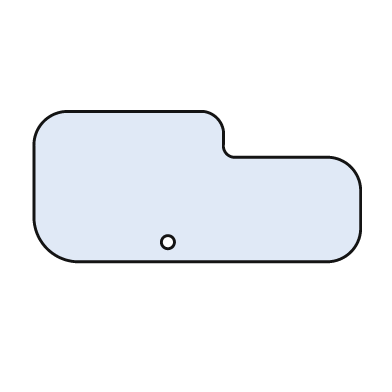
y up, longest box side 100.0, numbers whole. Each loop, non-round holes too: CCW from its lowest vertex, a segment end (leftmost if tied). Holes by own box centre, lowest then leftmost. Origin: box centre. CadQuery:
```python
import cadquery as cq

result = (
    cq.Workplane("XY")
    .moveTo(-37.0, -23.0)
    .lineTo(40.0, -23.0)
    .threePointArc((47.0, -20.0), (50.0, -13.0))
    .lineTo(50.0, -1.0)
    .threePointArc((47.0, 6.0), (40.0, 9.0))
    .lineTo(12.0, 9.0)
    .threePointArc((9.0, 10.0), (8.0, 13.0))
    .lineTo(8.0, 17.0)
    .threePointArc((6.0, 21.0), (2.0, 23.0))
    .lineTo(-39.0, 23.0)
    .threePointArc((-47.0, 20.0), (-50.0, 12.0))
    .lineTo(-50.0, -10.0)
    .threePointArc((-46.0, -19.0), (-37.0, -23.0))
    .close()
    .moveTo(-9.0, -17.0)
    .circle(2.0)
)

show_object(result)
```